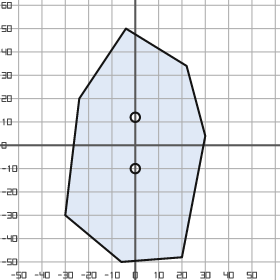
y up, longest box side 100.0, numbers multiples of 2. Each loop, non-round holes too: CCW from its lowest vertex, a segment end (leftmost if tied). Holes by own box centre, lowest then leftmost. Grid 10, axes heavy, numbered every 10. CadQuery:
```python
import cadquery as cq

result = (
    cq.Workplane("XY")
    .moveTo(-6.0, -50.0)
    .lineTo(20.0, -48.0)
    .lineTo(30.0, 4.0)
    .lineTo(22.0, 34.0)
    .lineTo(-4.0, 50.0)
    .lineTo(-24.0, 20.0)
    .lineTo(-30.0, -30.0)
    .close()
    .moveTo(0.0, -10.0)
    .circle(2.0)
    .moveTo(0.0, 12.0)
    .circle(2.0)
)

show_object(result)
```